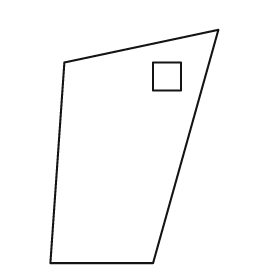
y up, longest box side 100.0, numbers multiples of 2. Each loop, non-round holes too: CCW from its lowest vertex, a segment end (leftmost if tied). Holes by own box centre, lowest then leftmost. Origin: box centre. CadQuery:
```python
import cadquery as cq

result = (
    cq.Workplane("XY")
    .moveTo(-36.0, -50.0)
    .lineTo(8.0, -50.0)
    .lineTo(36.0, 50.0)
    .lineTo(-30.0, 36.0)
    .close()
    .moveTo(8.0, 24.0)
    .lineTo(20.0, 24.0)
    .lineTo(20.0, 36.0)
    .lineTo(8.0, 36.0)
    .close()
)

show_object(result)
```